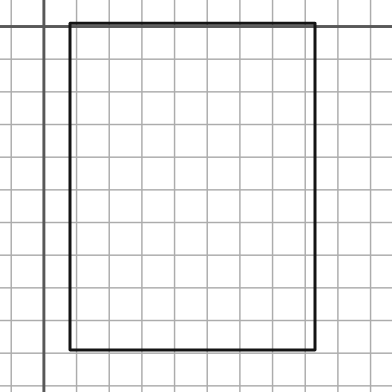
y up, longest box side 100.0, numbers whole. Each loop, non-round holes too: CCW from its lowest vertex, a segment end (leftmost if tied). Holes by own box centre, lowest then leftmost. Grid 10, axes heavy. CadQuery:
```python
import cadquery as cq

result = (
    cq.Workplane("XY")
    .moveTo(8.0, -99.0)
    .lineTo(83.0, -99.0)
    .lineTo(83.0, 1.0)
    .lineTo(8.0, 1.0)
    .close()
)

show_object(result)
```